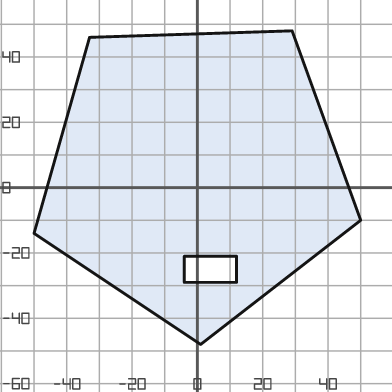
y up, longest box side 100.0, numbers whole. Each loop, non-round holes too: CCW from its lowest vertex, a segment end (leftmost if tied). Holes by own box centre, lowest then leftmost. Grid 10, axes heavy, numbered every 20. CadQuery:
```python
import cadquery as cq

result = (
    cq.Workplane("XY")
    .moveTo(1.0, -48.0)
    .lineTo(50.0, -10.0)
    .lineTo(29.0, 48.0)
    .lineTo(-33.0, 46.0)
    .lineTo(-50.0, -14.0)
    .close()
    .moveTo(-4.0, -29.0)
    .lineTo(12.0, -29.0)
    .lineTo(12.0, -21.0)
    .lineTo(-4.0, -21.0)
    .close()
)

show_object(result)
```